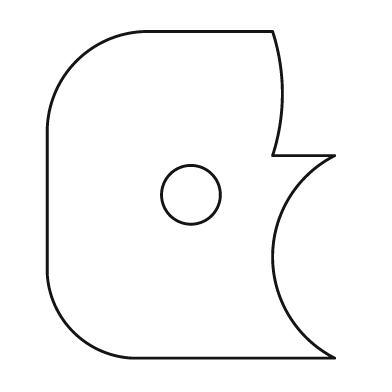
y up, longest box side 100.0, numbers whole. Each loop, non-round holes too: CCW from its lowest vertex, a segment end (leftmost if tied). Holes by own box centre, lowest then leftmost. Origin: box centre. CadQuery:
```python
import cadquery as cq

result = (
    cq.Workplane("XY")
    .moveTo(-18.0, -50.0)
    .lineTo(44.0, -50.0)
    .threePointArc((25.0, -19.0), (44.0, 12.0))
    .lineTo(25.0, 12.0)
    .threePointArc((28.0, 31.0), (25.0, 50.0))
    .lineTo(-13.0, 50.0)
    .threePointArc((-35.0, 41.0), (-44.0, 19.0))
    .lineTo(-44.0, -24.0)
    .threePointArc((-36.0, -42.0), (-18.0, -50.0))
    .close()
    .moveTo(0.0, 0.0)
    .circle(9.0)
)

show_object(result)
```